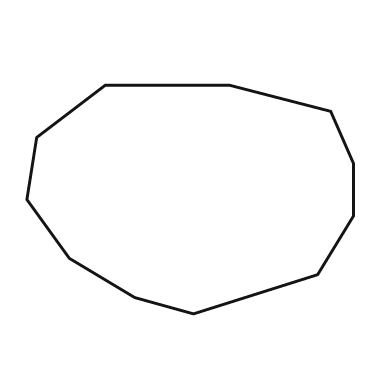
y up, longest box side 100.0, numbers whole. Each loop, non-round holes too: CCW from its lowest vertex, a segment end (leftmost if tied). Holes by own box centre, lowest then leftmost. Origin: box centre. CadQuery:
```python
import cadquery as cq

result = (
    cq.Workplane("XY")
    .moveTo(1.0, -35.0)
    .lineTo(39.0, -23.0)
    .lineTo(50.0, -5.0)
    .lineTo(50.0, 11.0)
    .lineTo(43.0, 27.0)
    .lineTo(12.0, 35.0)
    .lineTo(-26.0, 35.0)
    .lineTo(-47.0, 19.0)
    .lineTo(-50.0, 0.0)
    .lineTo(-37.0, -18.0)
    .lineTo(-17.0, -30.0)
    .close()
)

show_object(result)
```